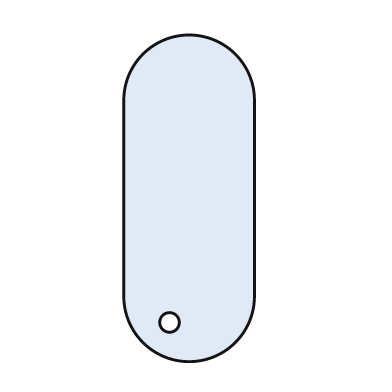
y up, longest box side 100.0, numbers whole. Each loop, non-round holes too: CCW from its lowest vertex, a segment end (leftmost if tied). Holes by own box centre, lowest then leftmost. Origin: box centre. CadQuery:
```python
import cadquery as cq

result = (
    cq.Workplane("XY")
    .moveTo(-20.0, -30.0)
    .threePointArc((0.0, -50.0), (20.0, -30.0))
    .lineTo(20.0, 30.0)
    .threePointArc((0.0, 50.0), (-20.0, 30.0))
    .close()
    .moveTo(-6.0, -38.0)
    .circle(3.0)
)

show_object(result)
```